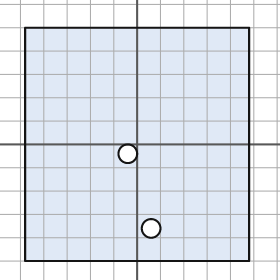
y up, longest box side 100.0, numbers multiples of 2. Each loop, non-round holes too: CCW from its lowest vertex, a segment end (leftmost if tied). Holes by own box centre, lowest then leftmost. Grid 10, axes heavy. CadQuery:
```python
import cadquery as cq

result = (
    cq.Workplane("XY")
    .moveTo(-48.0, -50.0)
    .lineTo(48.0, -50.0)
    .lineTo(48.0, 50.0)
    .lineTo(-48.0, 50.0)
    .close()
    .moveTo(6.0, -36.0)
    .circle(4.0)
    .moveTo(-4.0, -4.0)
    .circle(4.0)
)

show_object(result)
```